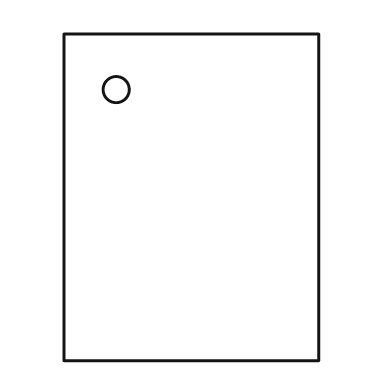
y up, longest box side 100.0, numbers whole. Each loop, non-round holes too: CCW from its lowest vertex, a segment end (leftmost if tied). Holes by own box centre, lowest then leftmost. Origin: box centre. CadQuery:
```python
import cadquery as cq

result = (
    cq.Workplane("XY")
    .moveTo(-39.0, -50.0)
    .lineTo(39.0, -50.0)
    .lineTo(39.0, 50.0)
    .lineTo(-39.0, 50.0)
    .close()
    .moveTo(-23.0, 33.0)
    .circle(4.0)
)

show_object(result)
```